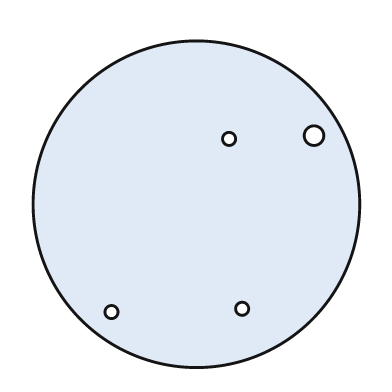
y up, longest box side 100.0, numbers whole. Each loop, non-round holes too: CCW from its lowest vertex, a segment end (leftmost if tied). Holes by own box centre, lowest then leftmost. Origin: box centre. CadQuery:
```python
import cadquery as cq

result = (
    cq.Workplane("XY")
    .moveTo(0.0, 0.0)
    .circle(50.0)
    .moveTo(-26.0, -33.0)
    .circle(2.0)
    .moveTo(14.0, -32.0)
    .circle(2.0)
    .moveTo(10.0, 20.0)
    .circle(2.0)
    .moveTo(36.0, 21.0)
    .circle(3.0)
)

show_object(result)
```